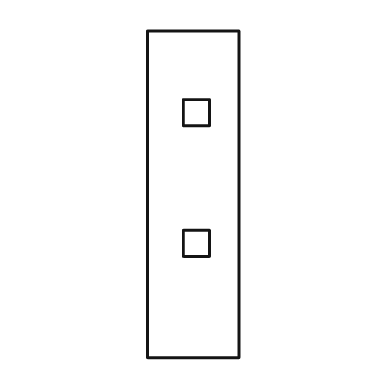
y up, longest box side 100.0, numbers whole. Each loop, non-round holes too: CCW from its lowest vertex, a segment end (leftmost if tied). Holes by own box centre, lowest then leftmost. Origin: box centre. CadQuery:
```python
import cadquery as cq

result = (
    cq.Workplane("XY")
    .moveTo(-14.0, -50.0)
    .lineTo(14.0, -50.0)
    .lineTo(14.0, 50.0)
    .lineTo(-14.0, 50.0)
    .close()
    .moveTo(-3.0, -19.0)
    .lineTo(5.0, -19.0)
    .lineTo(5.0, -11.0)
    .lineTo(-3.0, -11.0)
    .close()
    .moveTo(-3.0, 21.0)
    .lineTo(5.0, 21.0)
    .lineTo(5.0, 29.0)
    .lineTo(-3.0, 29.0)
    .close()
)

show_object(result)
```